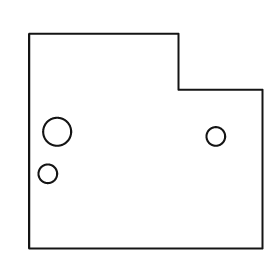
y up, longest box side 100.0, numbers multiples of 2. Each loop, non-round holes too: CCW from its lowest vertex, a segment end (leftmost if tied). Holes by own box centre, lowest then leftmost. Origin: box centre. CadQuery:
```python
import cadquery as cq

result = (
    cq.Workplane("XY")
    .moveTo(-50.0, -46.0)
    .lineTo(50.0, -46.0)
    .lineTo(50.0, 22.0)
    .lineTo(14.0, 22.0)
    .lineTo(14.0, 46.0)
    .lineTo(-50.0, 46.0)
    .close()
    .moveTo(-42.0, -14.0)
    .circle(4.0)
    .moveTo(30.0, 2.0)
    .circle(4.0)
    .moveTo(-38.0, 4.0)
    .circle(6.0)
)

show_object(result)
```